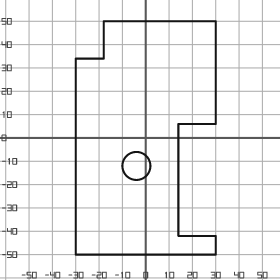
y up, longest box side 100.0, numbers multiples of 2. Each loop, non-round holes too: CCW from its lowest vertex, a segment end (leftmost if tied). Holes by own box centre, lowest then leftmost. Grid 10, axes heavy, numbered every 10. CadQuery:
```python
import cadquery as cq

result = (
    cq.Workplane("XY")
    .moveTo(-30.0, -50.0)
    .lineTo(30.0, -50.0)
    .lineTo(30.0, -42.0)
    .lineTo(14.0, -42.0)
    .lineTo(14.0, 6.0)
    .lineTo(30.0, 6.0)
    .lineTo(30.0, 50.0)
    .lineTo(-18.0, 50.0)
    .lineTo(-18.0, 34.0)
    .lineTo(-30.0, 34.0)
    .close()
    .moveTo(-4.0, -12.0)
    .circle(6.0)
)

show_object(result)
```